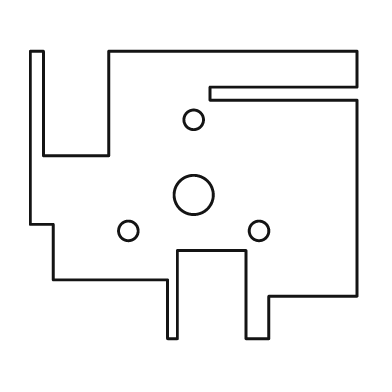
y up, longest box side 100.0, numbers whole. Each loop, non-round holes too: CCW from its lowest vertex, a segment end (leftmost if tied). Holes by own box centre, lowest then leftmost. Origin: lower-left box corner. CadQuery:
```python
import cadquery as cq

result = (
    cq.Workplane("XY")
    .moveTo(42.0, 0.0)
    .lineTo(45.0, 0.0)
    .lineTo(45.0, 27.0)
    .lineTo(66.0, 27.0)
    .lineTo(66.0, 0.0)
    .lineTo(73.0, 0.0)
    .lineTo(73.0, 13.0)
    .lineTo(100.0, 13.0)
    .lineTo(100.0, 73.0)
    .lineTo(55.0, 73.0)
    .lineTo(55.0, 77.0)
    .lineTo(100.0, 77.0)
    .lineTo(100.0, 88.0)
    .lineTo(24.0, 88.0)
    .lineTo(24.0, 56.0)
    .lineTo(4.0, 56.0)
    .lineTo(4.0, 88.0)
    .lineTo(0.0, 88.0)
    .lineTo(0.0, 35.0)
    .lineTo(7.0, 35.0)
    .lineTo(7.0, 18.0)
    .lineTo(42.0, 18.0)
    .close()
    .moveTo(30.0, 33.0)
    .circle(3.0)
    .moveTo(70.0, 33.0)
    .circle(3.0)
    .moveTo(50.0, 44.0)
    .circle(6.0)
    .moveTo(50.0, 67.0)
    .circle(3.0)
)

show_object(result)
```